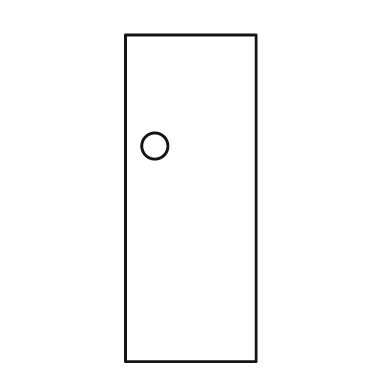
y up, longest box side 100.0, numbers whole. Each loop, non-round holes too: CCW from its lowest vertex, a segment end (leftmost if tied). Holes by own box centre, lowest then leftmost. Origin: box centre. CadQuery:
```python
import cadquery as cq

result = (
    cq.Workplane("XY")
    .moveTo(-20.0, -50.0)
    .lineTo(20.0, -50.0)
    .lineTo(20.0, 50.0)
    .lineTo(-20.0, 50.0)
    .close()
    .moveTo(-11.0, 16.0)
    .circle(4.0)
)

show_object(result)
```